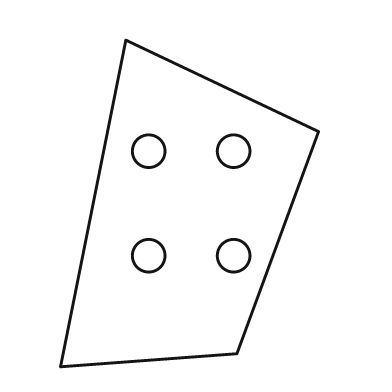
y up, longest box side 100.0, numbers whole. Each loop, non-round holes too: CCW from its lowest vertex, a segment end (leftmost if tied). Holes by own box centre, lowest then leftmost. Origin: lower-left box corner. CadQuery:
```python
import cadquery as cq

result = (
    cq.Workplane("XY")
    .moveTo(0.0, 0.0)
    .lineTo(54.0, 4.0)
    .lineTo(79.0, 72.0)
    .lineTo(20.0, 100.0)
    .close()
    .moveTo(27.0, 34.0)
    .circle(5.0)
    .moveTo(53.0, 34.0)
    .circle(5.0)
    .moveTo(27.0, 66.0)
    .circle(5.0)
    .moveTo(53.0, 66.0)
    .circle(5.0)
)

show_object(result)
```